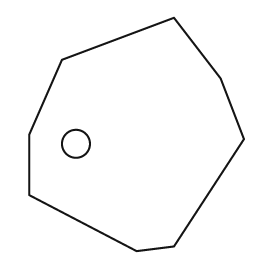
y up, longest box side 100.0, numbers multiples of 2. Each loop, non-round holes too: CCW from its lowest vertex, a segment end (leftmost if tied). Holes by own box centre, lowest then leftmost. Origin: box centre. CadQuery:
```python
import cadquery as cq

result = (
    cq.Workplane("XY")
    .moveTo(0.0, -50.0)
    .lineTo(16.0, -48.0)
    .lineTo(46.0, -2.0)
    .lineTo(36.0, 24.0)
    .lineTo(16.0, 50.0)
    .lineTo(-32.0, 32.0)
    .lineTo(-46.0, 0.0)
    .lineTo(-46.0, -26.0)
    .close()
    .moveTo(-26.0, -4.0)
    .circle(6.0)
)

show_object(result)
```